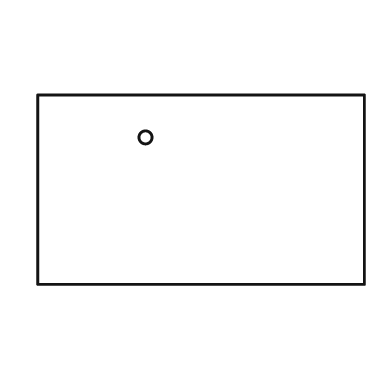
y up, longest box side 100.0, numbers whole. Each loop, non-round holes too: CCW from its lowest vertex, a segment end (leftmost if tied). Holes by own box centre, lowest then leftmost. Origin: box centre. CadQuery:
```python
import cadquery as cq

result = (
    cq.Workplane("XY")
    .moveTo(-50.0, -29.0)
    .lineTo(50.0, -29.0)
    .lineTo(50.0, 29.0)
    .lineTo(-50.0, 29.0)
    .close()
    .moveTo(-17.0, 16.0)
    .circle(2.0)
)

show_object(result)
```